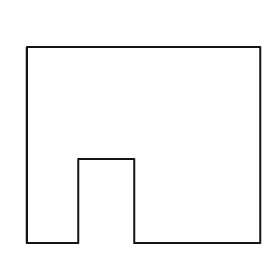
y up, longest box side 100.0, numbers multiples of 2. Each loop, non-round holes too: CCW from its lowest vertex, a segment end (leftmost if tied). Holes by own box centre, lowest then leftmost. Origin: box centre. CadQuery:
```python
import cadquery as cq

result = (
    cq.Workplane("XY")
    .moveTo(-50.0, -42.0)
    .lineTo(-28.0, -42.0)
    .lineTo(-28.0, -6.0)
    .lineTo(-4.0, -6.0)
    .lineTo(-4.0, -42.0)
    .lineTo(50.0, -42.0)
    .lineTo(50.0, 42.0)
    .lineTo(-50.0, 42.0)
    .close()
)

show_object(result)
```